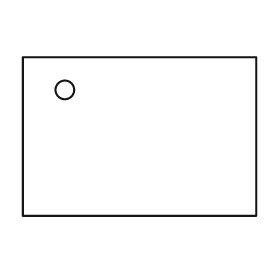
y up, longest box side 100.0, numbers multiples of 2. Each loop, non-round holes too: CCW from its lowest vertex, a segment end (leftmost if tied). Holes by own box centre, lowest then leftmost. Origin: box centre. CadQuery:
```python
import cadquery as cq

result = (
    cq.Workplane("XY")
    .moveTo(-50.0, -34.0)
    .lineTo(50.0, -34.0)
    .lineTo(50.0, 34.0)
    .lineTo(-50.0, 34.0)
    .close()
    .moveTo(-32.0, 20.0)
    .circle(4.0)
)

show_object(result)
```